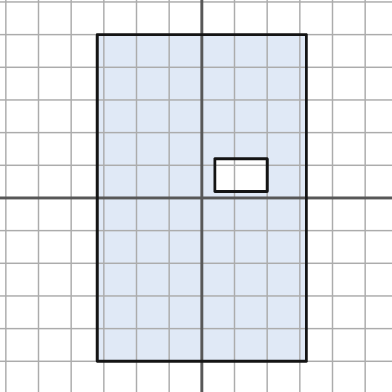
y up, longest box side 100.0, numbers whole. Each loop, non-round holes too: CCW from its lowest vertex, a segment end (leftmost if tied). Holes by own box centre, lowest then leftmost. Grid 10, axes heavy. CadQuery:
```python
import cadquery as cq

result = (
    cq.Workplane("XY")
    .moveTo(-32.0, -50.0)
    .lineTo(32.0, -50.0)
    .lineTo(32.0, 50.0)
    .lineTo(-32.0, 50.0)
    .close()
    .moveTo(4.0, 2.0)
    .lineTo(20.0, 2.0)
    .lineTo(20.0, 12.0)
    .lineTo(4.0, 12.0)
    .close()
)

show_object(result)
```